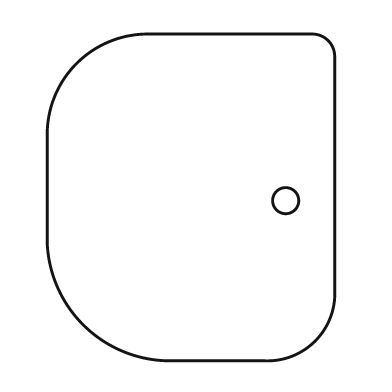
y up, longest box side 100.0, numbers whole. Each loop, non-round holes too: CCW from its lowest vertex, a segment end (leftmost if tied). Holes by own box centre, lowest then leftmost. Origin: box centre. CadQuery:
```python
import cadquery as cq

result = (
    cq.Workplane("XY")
    .moveTo(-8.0, -50.0)
    .lineTo(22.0, -50.0)
    .threePointArc((38.0, -44.0), (44.0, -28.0))
    .lineTo(44.0, 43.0)
    .threePointArc((42.0, 48.0), (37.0, 50.0))
    .lineTo(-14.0, 50.0)
    .threePointArc((-35.0, 41.0), (-44.0, 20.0))
    .lineTo(-44.0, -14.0)
    .threePointArc((-33.0, -39.0), (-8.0, -50.0))
    .close()
    .moveTo(29.0, -1.0)
    .circle(4.0)
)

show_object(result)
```